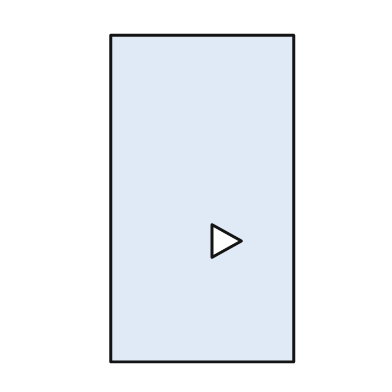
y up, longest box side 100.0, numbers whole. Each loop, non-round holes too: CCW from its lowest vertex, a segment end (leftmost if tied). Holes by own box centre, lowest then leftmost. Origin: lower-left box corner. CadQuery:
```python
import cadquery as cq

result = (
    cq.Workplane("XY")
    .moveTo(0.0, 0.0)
    .lineTo(56.0, 0.0)
    .lineTo(56.0, 100.0)
    .lineTo(0.0, 100.0)
    .close()
    .moveTo(31.0, 32.0)
    .lineTo(40.0, 37.0)
    .lineTo(31.0, 42.0)
    .close()
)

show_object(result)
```